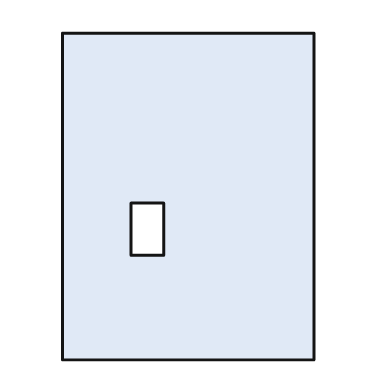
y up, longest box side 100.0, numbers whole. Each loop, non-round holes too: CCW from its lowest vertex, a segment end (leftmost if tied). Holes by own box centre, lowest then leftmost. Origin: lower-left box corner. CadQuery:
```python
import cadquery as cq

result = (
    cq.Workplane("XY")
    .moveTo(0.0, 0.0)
    .lineTo(77.0, 0.0)
    .lineTo(77.0, 100.0)
    .lineTo(0.0, 100.0)
    .close()
    .moveTo(21.0, 32.0)
    .lineTo(31.0, 32.0)
    .lineTo(31.0, 48.0)
    .lineTo(21.0, 48.0)
    .close()
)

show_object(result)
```